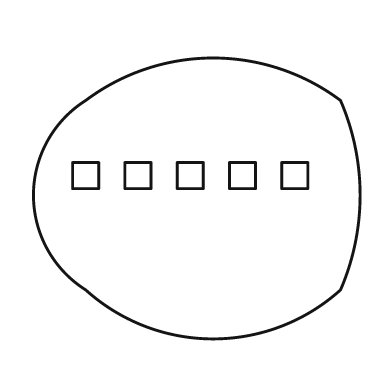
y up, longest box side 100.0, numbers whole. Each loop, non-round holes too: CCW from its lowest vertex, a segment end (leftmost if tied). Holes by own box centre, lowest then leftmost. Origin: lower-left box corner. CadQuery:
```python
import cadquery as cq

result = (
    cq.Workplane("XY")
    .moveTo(16.0, 15.0)
    .threePointArc((55.0, 0.0), (94.0, 15.0))
    .threePointArc((100.0, 44.0), (94.0, 73.0))
    .threePointArc((55.0, 86.0), (16.0, 73.0))
    .threePointArc((0.0, 44.0), (16.0, 15.0))
    .close()
    .moveTo(12.0, 46.0)
    .lineTo(20.0, 46.0)
    .lineTo(20.0, 54.0)
    .lineTo(12.0, 54.0)
    .close()
    .moveTo(28.0, 46.0)
    .lineTo(36.0, 46.0)
    .lineTo(36.0, 54.0)
    .lineTo(28.0, 54.0)
    .close()
    .moveTo(44.0, 46.0)
    .lineTo(52.0, 46.0)
    .lineTo(52.0, 54.0)
    .lineTo(44.0, 54.0)
    .close()
    .moveTo(60.0, 46.0)
    .lineTo(68.0, 46.0)
    .lineTo(68.0, 54.0)
    .lineTo(60.0, 54.0)
    .close()
    .moveTo(76.0, 46.0)
    .lineTo(84.0, 46.0)
    .lineTo(84.0, 54.0)
    .lineTo(76.0, 54.0)
    .close()
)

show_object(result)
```